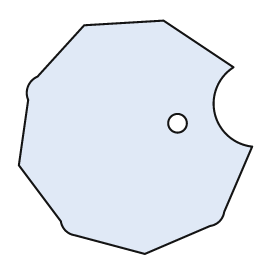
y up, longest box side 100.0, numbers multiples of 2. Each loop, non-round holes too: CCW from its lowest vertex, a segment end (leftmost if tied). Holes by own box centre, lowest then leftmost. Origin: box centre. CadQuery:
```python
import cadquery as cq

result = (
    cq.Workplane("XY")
    .moveTo(4.0, -50.0)
    .lineTo(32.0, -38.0)
    .threePointArc((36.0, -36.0), (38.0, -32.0))
    .lineTo(50.0, -4.0)
    .threePointArc((34.0, 10.0), (42.0, 30.0))
    .lineTo(12.0, 50.0)
    .lineTo(-22.0, 48.0)
    .lineTo(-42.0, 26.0)
    .threePointArc((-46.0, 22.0), (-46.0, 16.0))
    .lineTo(-50.0, -12.0)
    .lineTo(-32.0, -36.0)
    .threePointArc((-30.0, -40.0), (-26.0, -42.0))
    .close()
    .moveTo(18.0, 6.0)
    .circle(4.0)
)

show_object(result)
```